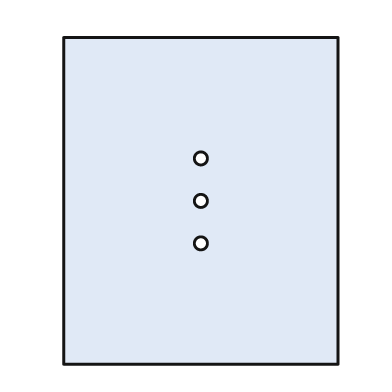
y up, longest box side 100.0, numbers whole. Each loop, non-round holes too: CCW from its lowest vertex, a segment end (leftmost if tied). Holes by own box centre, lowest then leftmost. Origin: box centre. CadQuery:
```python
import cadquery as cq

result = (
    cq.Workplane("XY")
    .moveTo(-42.0, -50.0)
    .lineTo(42.0, -50.0)
    .lineTo(42.0, 50.0)
    .lineTo(-42.0, 50.0)
    .close()
    .moveTo(0.0, -13.0)
    .circle(2.0)
    .moveTo(0.0, 0.0)
    .circle(2.0)
    .moveTo(0.0, 13.0)
    .circle(2.0)
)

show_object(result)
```